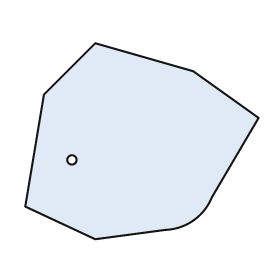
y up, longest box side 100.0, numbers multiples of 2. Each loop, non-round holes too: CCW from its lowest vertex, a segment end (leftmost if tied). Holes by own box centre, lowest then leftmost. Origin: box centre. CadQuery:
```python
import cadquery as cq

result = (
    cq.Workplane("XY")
    .moveTo(-20.0, -42.0)
    .lineTo(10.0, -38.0)
    .threePointArc((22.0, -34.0), (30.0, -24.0))
    .lineTo(50.0, 10.0)
    .lineTo(22.0, 30.0)
    .lineTo(-20.0, 42.0)
    .lineTo(-42.0, 20.0)
    .lineTo(-50.0, -28.0)
    .close()
    .moveTo(-30.0, -8.0)
    .circle(2.0)
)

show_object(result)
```